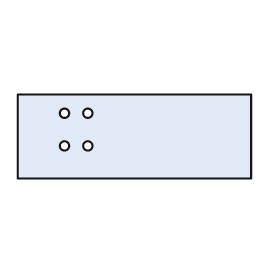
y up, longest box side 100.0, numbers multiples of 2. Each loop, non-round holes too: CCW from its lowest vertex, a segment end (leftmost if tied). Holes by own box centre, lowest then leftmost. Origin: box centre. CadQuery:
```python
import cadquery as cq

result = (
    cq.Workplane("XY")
    .moveTo(-50.0, -18.0)
    .lineTo(50.0, -18.0)
    .lineTo(50.0, 18.0)
    .lineTo(-50.0, 18.0)
    .close()
    .moveTo(-30.0, -4.0)
    .circle(2.0)
    .moveTo(-20.0, -4.0)
    .circle(2.0)
    .moveTo(-30.0, 10.0)
    .circle(2.0)
    .moveTo(-20.0, 10.0)
    .circle(2.0)
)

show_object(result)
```